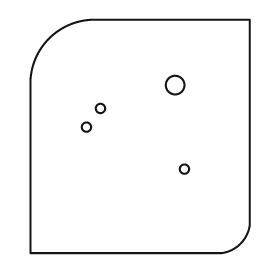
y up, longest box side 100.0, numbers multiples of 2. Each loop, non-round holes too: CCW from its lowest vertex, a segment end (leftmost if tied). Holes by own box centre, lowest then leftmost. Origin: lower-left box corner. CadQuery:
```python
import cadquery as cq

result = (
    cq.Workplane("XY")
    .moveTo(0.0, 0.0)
    .lineTo(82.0, 0.0)
    .threePointArc((90.0, 4.0), (94.0, 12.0))
    .lineTo(94.0, 100.0)
    .lineTo(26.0, 100.0)
    .threePointArc((8.0, 92.0), (0.0, 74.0))
    .close()
    .moveTo(66.0, 36.0)
    .circle(2.0)
    .moveTo(24.0, 54.0)
    .circle(2.0)
    .moveTo(30.0, 62.0)
    .circle(2.0)
    .moveTo(62.0, 72.0)
    .circle(4.0)
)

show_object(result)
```